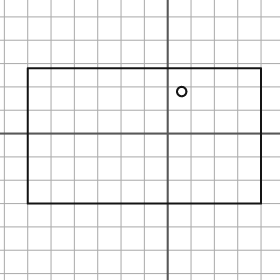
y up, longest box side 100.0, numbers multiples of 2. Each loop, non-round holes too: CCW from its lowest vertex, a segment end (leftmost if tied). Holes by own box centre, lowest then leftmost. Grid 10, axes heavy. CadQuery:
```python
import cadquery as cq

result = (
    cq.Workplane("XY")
    .moveTo(-60.0, -30.0)
    .lineTo(40.0, -30.0)
    .lineTo(40.0, 28.0)
    .lineTo(-60.0, 28.0)
    .close()
    .moveTo(6.0, 18.0)
    .circle(2.0)
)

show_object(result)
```